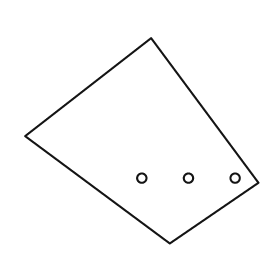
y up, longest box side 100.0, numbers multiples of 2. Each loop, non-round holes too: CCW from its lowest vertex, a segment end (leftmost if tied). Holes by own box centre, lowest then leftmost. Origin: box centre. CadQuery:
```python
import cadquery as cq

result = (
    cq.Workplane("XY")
    .moveTo(12.0, -44.0)
    .lineTo(50.0, -18.0)
    .lineTo(4.0, 44.0)
    .lineTo(-50.0, 2.0)
    .close()
    .moveTo(0.0, -16.0)
    .circle(2.0)
    .moveTo(20.0, -16.0)
    .circle(2.0)
    .moveTo(40.0, -16.0)
    .circle(2.0)
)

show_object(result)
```